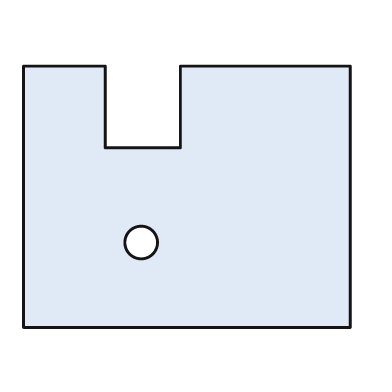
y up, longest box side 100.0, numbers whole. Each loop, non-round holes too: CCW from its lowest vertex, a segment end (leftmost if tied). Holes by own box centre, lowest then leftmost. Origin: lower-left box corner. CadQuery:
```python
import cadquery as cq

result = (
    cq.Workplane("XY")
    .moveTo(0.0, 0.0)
    .lineTo(100.0, 0.0)
    .lineTo(100.0, 80.0)
    .lineTo(48.0, 80.0)
    .lineTo(48.0, 55.0)
    .lineTo(25.0, 55.0)
    .lineTo(25.0, 80.0)
    .lineTo(0.0, 80.0)
    .close()
    .moveTo(36.0, 26.0)
    .circle(5.0)
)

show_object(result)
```